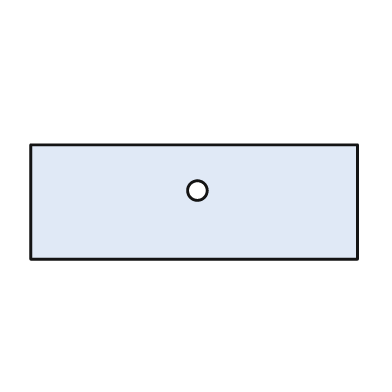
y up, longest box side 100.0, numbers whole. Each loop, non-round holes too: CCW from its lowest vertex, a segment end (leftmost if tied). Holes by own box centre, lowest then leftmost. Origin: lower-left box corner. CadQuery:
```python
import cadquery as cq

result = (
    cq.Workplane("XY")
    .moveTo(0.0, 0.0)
    .lineTo(100.0, 0.0)
    .lineTo(100.0, 35.0)
    .lineTo(0.0, 35.0)
    .close()
    .moveTo(51.0, 21.0)
    .circle(3.0)
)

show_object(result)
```